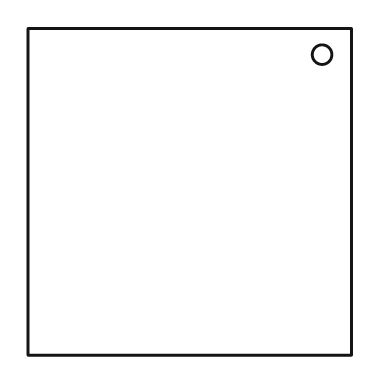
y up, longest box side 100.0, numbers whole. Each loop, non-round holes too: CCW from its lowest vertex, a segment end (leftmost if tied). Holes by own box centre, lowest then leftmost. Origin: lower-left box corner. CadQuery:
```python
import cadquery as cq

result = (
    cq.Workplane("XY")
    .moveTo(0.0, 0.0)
    .lineTo(99.0, 0.0)
    .lineTo(99.0, 100.0)
    .lineTo(0.0, 100.0)
    .close()
    .moveTo(90.0, 92.0)
    .circle(3.0)
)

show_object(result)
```